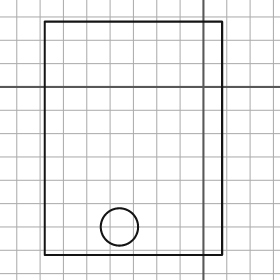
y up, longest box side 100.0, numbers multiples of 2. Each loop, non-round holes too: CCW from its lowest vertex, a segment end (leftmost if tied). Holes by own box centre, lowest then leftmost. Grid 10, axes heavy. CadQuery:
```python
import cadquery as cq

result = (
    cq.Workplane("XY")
    .moveTo(-68.0, -72.0)
    .lineTo(8.0, -72.0)
    .lineTo(8.0, 28.0)
    .lineTo(-68.0, 28.0)
    .close()
    .moveTo(-36.0, -60.0)
    .circle(8.0)
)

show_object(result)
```